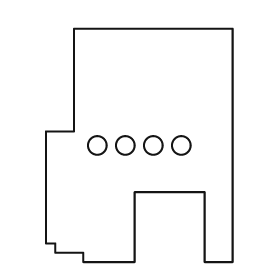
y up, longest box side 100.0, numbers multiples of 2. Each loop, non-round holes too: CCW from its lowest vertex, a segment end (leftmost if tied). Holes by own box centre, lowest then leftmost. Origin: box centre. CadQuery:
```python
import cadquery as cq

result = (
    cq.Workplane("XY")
    .moveTo(-24.0, -50.0)
    .lineTo(-2.0, -50.0)
    .lineTo(-2.0, -20.0)
    .lineTo(28.0, -20.0)
    .lineTo(28.0, -50.0)
    .lineTo(40.0, -50.0)
    .lineTo(40.0, 50.0)
    .lineTo(-28.0, 50.0)
    .lineTo(-28.0, 6.0)
    .lineTo(-40.0, 6.0)
    .lineTo(-40.0, -42.0)
    .lineTo(-36.0, -42.0)
    .lineTo(-36.0, -46.0)
    .lineTo(-24.0, -46.0)
    .close()
    .moveTo(-18.0, 0.0)
    .circle(4.0)
    .moveTo(-6.0, 0.0)
    .circle(4.0)
    .moveTo(6.0, 0.0)
    .circle(4.0)
    .moveTo(18.0, 0.0)
    .circle(4.0)
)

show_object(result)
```